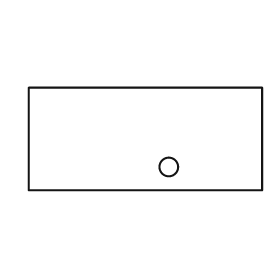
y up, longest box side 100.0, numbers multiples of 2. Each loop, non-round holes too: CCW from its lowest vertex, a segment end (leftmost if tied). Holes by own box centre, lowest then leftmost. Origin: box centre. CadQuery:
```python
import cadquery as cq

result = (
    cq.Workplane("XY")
    .moveTo(-50.0, -22.0)
    .lineTo(50.0, -22.0)
    .lineTo(50.0, 22.0)
    .lineTo(-50.0, 22.0)
    .close()
    .moveTo(10.0, -12.0)
    .circle(4.0)
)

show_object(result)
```